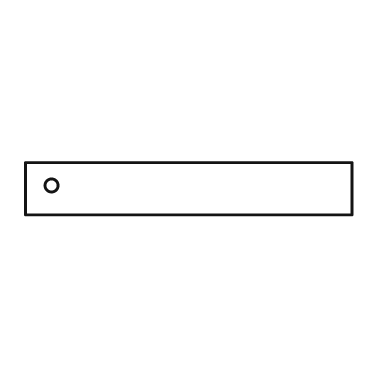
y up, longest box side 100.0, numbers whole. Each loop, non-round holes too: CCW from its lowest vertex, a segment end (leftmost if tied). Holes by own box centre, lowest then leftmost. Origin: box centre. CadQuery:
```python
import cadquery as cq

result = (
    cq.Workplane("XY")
    .moveTo(-50.0, -8.0)
    .lineTo(50.0, -8.0)
    .lineTo(50.0, 8.0)
    .lineTo(-50.0, 8.0)
    .close()
    .moveTo(-42.0, 1.0)
    .circle(2.0)
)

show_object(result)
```